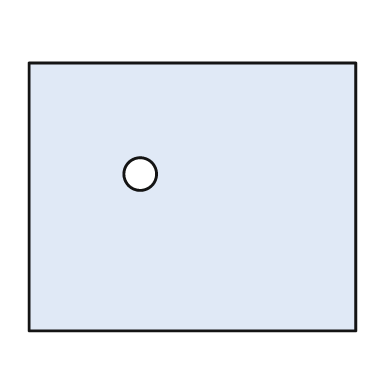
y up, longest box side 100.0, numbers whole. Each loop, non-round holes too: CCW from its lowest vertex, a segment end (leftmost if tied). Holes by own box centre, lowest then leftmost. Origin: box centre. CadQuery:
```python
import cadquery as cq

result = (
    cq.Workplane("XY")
    .moveTo(-50.0, -41.0)
    .lineTo(50.0, -41.0)
    .lineTo(50.0, 41.0)
    .lineTo(-50.0, 41.0)
    .close()
    .moveTo(-16.0, 7.0)
    .circle(5.0)
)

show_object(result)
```